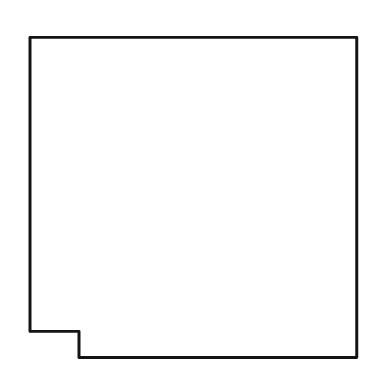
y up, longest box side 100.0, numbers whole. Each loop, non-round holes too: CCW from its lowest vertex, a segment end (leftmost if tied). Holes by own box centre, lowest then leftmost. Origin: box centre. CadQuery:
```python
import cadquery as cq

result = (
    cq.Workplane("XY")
    .moveTo(-35.0, -49.0)
    .lineTo(50.0, -49.0)
    .lineTo(50.0, 49.0)
    .lineTo(-50.0, 49.0)
    .lineTo(-50.0, -41.0)
    .lineTo(-35.0, -41.0)
    .close()
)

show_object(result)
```